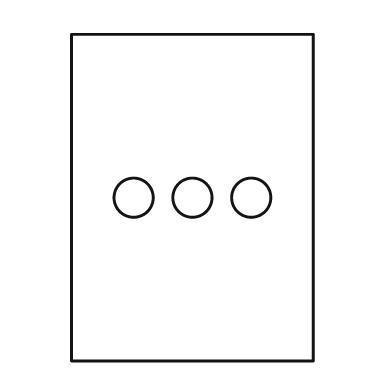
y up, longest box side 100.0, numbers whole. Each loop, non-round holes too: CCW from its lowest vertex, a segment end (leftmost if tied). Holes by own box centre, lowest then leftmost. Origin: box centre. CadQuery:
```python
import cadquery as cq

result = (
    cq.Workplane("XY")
    .moveTo(-37.0, -50.0)
    .lineTo(37.0, -50.0)
    .lineTo(37.0, 50.0)
    .lineTo(-37.0, 50.0)
    .close()
    .moveTo(-18.0, 0.0)
    .circle(6.0)
    .moveTo(0.0, 0.0)
    .circle(6.0)
    .moveTo(18.0, 0.0)
    .circle(6.0)
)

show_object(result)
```